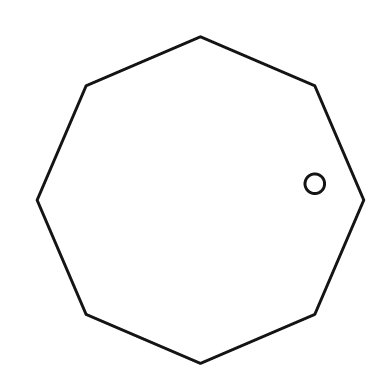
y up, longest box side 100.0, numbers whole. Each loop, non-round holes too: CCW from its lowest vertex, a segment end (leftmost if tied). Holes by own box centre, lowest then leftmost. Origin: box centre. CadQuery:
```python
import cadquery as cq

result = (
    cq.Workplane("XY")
    .moveTo(0.0, -50.0)
    .lineTo(35.0, -35.0)
    .lineTo(50.0, 0.0)
    .lineTo(35.0, 35.0)
    .lineTo(0.0, 50.0)
    .lineTo(-35.0, 35.0)
    .lineTo(-50.0, 0.0)
    .lineTo(-35.0, -35.0)
    .close()
    .moveTo(35.0, 5.0)
    .circle(3.0)
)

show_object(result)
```